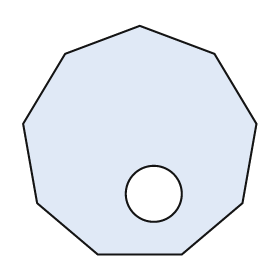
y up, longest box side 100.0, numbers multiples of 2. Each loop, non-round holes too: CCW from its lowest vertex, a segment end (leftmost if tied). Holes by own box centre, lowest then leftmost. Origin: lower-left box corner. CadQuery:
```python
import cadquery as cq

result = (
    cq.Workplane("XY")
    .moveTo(32.0, 0.0)
    .lineTo(68.0, 0.0)
    .lineTo(94.0, 22.0)
    .lineTo(100.0, 56.0)
    .lineTo(82.0, 86.0)
    .lineTo(50.0, 98.0)
    .lineTo(18.0, 86.0)
    .lineTo(0.0, 56.0)
    .lineTo(6.0, 22.0)
    .close()
    .moveTo(56.0, 26.0)
    .circle(12.0)
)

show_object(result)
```